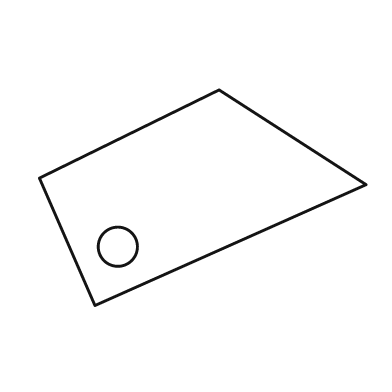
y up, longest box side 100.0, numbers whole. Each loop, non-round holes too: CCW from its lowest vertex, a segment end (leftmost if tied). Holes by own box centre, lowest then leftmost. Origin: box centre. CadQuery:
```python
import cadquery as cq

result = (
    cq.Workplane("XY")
    .moveTo(-33.0, -33.0)
    .lineTo(50.0, 4.0)
    .lineTo(5.0, 33.0)
    .lineTo(-50.0, 6.0)
    .close()
    .moveTo(-26.0, -15.0)
    .circle(6.0)
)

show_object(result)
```